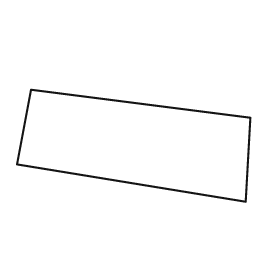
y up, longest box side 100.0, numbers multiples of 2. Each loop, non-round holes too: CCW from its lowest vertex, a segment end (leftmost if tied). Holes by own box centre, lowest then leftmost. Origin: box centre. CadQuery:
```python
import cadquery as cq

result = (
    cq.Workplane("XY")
    .moveTo(48.0, -24.0)
    .lineTo(50.0, 12.0)
    .lineTo(-44.0, 24.0)
    .lineTo(-50.0, -8.0)
    .close()
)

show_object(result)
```